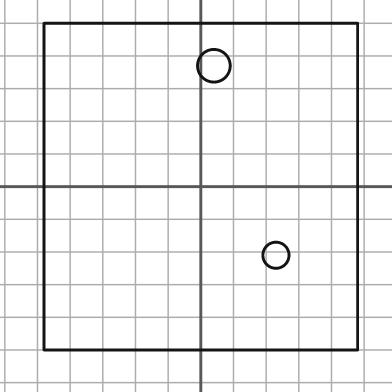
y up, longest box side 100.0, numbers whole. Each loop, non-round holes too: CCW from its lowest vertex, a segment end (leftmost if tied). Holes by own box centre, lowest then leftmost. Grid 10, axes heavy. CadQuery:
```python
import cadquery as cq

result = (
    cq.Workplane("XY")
    .moveTo(-48.0, -50.0)
    .lineTo(48.0, -50.0)
    .lineTo(48.0, 50.0)
    .lineTo(-48.0, 50.0)
    .close()
    .moveTo(23.0, -21.0)
    .circle(4.0)
    .moveTo(4.0, 37.0)
    .circle(5.0)
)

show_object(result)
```